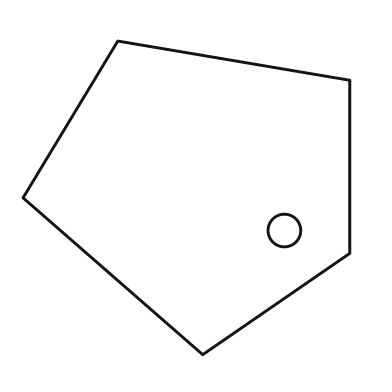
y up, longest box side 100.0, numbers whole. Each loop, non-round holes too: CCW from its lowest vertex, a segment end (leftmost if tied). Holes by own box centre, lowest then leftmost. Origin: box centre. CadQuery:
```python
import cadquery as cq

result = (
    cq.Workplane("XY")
    .moveTo(5.0, -48.0)
    .lineTo(50.0, -17.0)
    .lineTo(50.0, 36.0)
    .lineTo(-21.0, 48.0)
    .lineTo(-50.0, 0.0)
    .close()
    .moveTo(30.0, -10.0)
    .circle(5.0)
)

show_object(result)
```